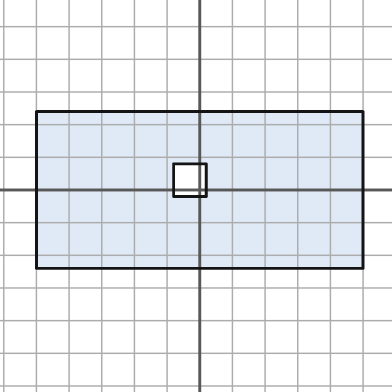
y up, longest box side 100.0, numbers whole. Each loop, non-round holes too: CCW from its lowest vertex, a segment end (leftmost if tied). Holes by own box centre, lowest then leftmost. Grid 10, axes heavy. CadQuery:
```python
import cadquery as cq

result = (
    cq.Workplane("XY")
    .moveTo(-50.0, -24.0)
    .lineTo(50.0, -24.0)
    .lineTo(50.0, 24.0)
    .lineTo(-50.0, 24.0)
    .close()
    .moveTo(-8.0, -2.0)
    .lineTo(2.0, -2.0)
    .lineTo(2.0, 8.0)
    .lineTo(-8.0, 8.0)
    .close()
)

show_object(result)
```